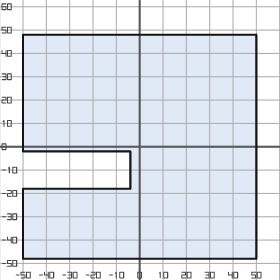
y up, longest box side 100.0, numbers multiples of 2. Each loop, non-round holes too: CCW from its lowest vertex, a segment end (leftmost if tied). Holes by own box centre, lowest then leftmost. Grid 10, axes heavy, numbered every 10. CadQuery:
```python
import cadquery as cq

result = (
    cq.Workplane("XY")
    .moveTo(-50.0, -48.0)
    .lineTo(50.0, -48.0)
    .lineTo(50.0, 48.0)
    .lineTo(-50.0, 48.0)
    .lineTo(-50.0, -2.0)
    .lineTo(-4.0, -2.0)
    .lineTo(-4.0, -18.0)
    .lineTo(-50.0, -18.0)
    .close()
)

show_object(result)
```